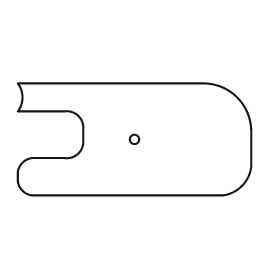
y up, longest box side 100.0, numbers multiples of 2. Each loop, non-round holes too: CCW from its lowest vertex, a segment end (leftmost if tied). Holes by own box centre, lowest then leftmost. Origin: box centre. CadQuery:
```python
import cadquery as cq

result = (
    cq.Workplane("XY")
    .moveTo(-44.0, -24.0)
    .lineTo(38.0, -24.0)
    .threePointArc((46.0, -20.0), (50.0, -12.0))
    .lineTo(50.0, 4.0)
    .threePointArc((44.0, 18.0), (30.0, 24.0))
    .lineTo(-50.0, 24.0)
    .threePointArc((-48.0, 18.0), (-50.0, 12.0))
    .lineTo(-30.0, 12.0)
    .threePointArc((-24.0, 10.0), (-22.0, 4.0))
    .lineTo(-22.0, 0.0)
    .threePointArc((-24.0, -6.0), (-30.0, -8.0))
    .lineTo(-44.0, -8.0)
    .threePointArc((-48.0, -10.0), (-50.0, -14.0))
    .lineTo(-50.0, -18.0)
    .threePointArc((-48.0, -22.0), (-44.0, -24.0))
    .close()
    .moveTo(0.0, 0.0)
    .circle(2.0)
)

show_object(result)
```